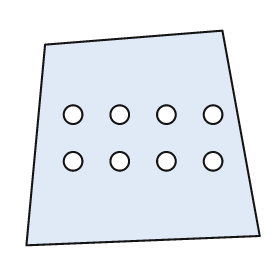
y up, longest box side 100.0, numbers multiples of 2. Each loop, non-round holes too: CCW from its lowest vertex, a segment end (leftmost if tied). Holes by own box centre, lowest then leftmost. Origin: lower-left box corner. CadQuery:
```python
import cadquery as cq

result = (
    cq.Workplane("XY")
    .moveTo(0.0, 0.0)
    .lineTo(100.0, 4.0)
    .lineTo(84.0, 92.0)
    .lineTo(8.0, 86.0)
    .close()
    .moveTo(20.0, 36.0)
    .circle(4.0)
    .moveTo(40.0, 36.0)
    .circle(4.0)
    .moveTo(60.0, 36.0)
    .circle(4.0)
    .moveTo(80.0, 36.0)
    .circle(4.0)
    .moveTo(20.0, 56.0)
    .circle(4.0)
    .moveTo(40.0, 56.0)
    .circle(4.0)
    .moveTo(60.0, 56.0)
    .circle(4.0)
    .moveTo(80.0, 56.0)
    .circle(4.0)
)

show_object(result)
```